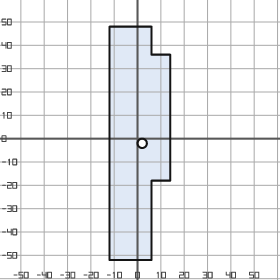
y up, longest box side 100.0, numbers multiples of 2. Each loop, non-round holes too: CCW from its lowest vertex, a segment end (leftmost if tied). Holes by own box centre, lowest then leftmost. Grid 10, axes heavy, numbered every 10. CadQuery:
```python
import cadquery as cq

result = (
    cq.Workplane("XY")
    .moveTo(-12.0, -52.0)
    .lineTo(6.0, -52.0)
    .lineTo(6.0, -18.0)
    .lineTo(14.0, -18.0)
    .lineTo(14.0, 36.0)
    .lineTo(6.0, 36.0)
    .lineTo(6.0, 48.0)
    .lineTo(-12.0, 48.0)
    .close()
    .moveTo(2.0, -2.0)
    .circle(2.0)
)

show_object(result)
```